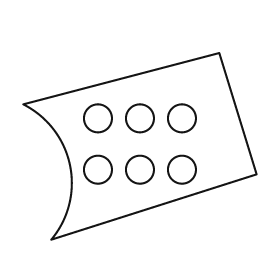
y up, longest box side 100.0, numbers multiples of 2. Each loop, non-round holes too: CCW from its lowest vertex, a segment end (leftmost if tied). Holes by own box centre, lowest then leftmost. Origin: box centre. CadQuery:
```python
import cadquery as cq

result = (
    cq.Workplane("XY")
    .moveTo(-38.0, -40.0)
    .lineTo(50.0, -12.0)
    .lineTo(34.0, 40.0)
    .lineTo(-50.0, 18.0)
    .threePointArc((-30.0, -8.0), (-38.0, -40.0))
    .close()
    .moveTo(-18.0, -10.0)
    .circle(6.0)
    .moveTo(0.0, -10.0)
    .circle(6.0)
    .moveTo(18.0, -10.0)
    .circle(6.0)
    .moveTo(-18.0, 12.0)
    .circle(6.0)
    .moveTo(0.0, 12.0)
    .circle(6.0)
    .moveTo(18.0, 12.0)
    .circle(6.0)
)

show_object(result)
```